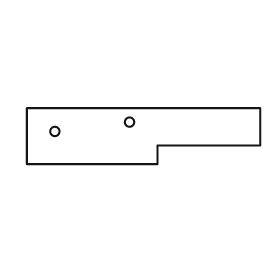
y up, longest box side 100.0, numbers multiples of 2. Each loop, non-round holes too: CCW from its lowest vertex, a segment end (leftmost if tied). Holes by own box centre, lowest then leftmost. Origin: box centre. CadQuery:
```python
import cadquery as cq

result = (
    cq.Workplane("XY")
    .moveTo(-50.0, -12.0)
    .lineTo(6.0, -12.0)
    .lineTo(6.0, -4.0)
    .lineTo(50.0, -4.0)
    .lineTo(50.0, 12.0)
    .lineTo(-50.0, 12.0)
    .close()
    .moveTo(-38.0, 2.0)
    .circle(2.0)
    .moveTo(-6.0, 6.0)
    .circle(2.0)
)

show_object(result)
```